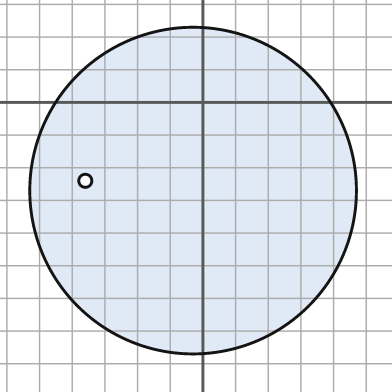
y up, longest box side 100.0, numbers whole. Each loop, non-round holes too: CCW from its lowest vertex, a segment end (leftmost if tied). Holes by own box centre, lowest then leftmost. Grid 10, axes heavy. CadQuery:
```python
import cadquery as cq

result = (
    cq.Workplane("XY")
    .moveTo(-3.0, -27.0)
    .circle(50.0)
    .moveTo(-36.0, -24.0)
    .circle(2.0)
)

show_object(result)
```